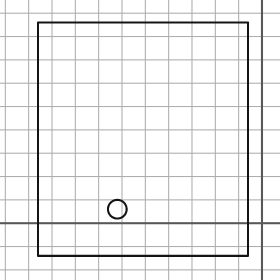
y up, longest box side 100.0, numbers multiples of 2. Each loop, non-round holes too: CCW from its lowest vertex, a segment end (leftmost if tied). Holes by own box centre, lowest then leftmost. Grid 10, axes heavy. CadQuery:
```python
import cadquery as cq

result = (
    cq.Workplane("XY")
    .moveTo(-96.0, -14.0)
    .lineTo(-6.0, -14.0)
    .lineTo(-6.0, 86.0)
    .lineTo(-96.0, 86.0)
    .close()
    .moveTo(-62.0, 6.0)
    .circle(4.0)
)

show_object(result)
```